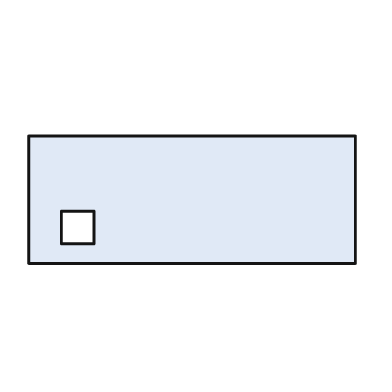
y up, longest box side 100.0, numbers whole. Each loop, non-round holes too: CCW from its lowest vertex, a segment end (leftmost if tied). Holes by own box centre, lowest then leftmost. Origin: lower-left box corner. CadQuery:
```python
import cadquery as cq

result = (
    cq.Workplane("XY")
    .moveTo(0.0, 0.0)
    .lineTo(100.0, 0.0)
    .lineTo(100.0, 39.0)
    .lineTo(0.0, 39.0)
    .close()
    .moveTo(10.0, 6.0)
    .lineTo(20.0, 6.0)
    .lineTo(20.0, 16.0)
    .lineTo(10.0, 16.0)
    .close()
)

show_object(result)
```